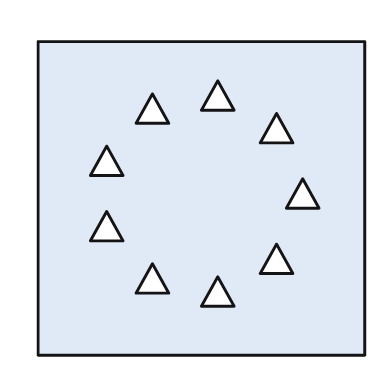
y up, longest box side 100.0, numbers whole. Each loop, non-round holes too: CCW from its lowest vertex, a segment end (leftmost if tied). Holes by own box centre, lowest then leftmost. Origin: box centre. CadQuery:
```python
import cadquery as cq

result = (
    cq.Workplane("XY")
    .moveTo(-50.0, -48.0)
    .lineTo(50.0, -48.0)
    .lineTo(50.0, 48.0)
    .lineTo(-50.0, 48.0)
    .close()
    .moveTo(0.0, -33.0)
    .lineTo(10.0, -33.0)
    .lineTo(5.0, -24.0)
    .close()
    .moveTo(-20.0, -29.0)
    .lineTo(-10.0, -29.0)
    .lineTo(-15.0, -20.0)
    .close()
    .moveTo(18.0, -23.0)
    .lineTo(28.0, -23.0)
    .lineTo(23.0, -14.0)
    .close()
    .moveTo(-34.0, -13.0)
    .lineTo(-24.0, -13.0)
    .lineTo(-29.0, -4.0)
    .close()
    .moveTo(26.0, -3.0)
    .lineTo(36.0, -3.0)
    .lineTo(31.0, 6.0)
    .close()
    .moveTo(-34.0, 7.0)
    .lineTo(-24.0, 7.0)
    .lineTo(-29.0, 16.0)
    .close()
    .moveTo(18.0, 17.0)
    .lineTo(28.0, 17.0)
    .lineTo(23.0, 26.0)
    .close()
    .moveTo(-20.0, 23.0)
    .lineTo(-10.0, 23.0)
    .lineTo(-15.0, 32.0)
    .close()
    .moveTo(0.0, 27.0)
    .lineTo(10.0, 27.0)
    .lineTo(5.0, 36.0)
    .close()
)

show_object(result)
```